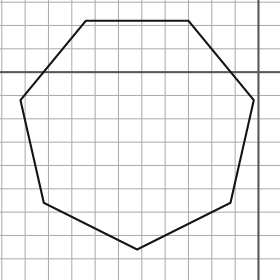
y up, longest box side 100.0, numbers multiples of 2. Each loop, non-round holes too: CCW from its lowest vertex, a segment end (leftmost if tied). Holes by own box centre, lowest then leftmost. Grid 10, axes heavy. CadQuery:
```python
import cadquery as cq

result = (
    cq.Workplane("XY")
    .moveTo(-52.0, -76.0)
    .lineTo(-12.0, -56.0)
    .lineTo(-2.0, -12.0)
    .lineTo(-30.0, 22.0)
    .lineTo(-74.0, 22.0)
    .lineTo(-102.0, -12.0)
    .lineTo(-92.0, -56.0)
    .close()
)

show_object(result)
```